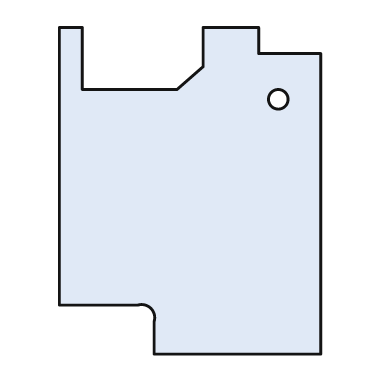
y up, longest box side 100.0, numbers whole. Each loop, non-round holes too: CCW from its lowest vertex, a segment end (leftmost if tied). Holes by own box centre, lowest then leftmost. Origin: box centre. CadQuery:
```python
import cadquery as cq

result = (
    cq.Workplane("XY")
    .moveTo(-11.0, -50.0)
    .lineTo(40.0, -50.0)
    .lineTo(40.0, 42.0)
    .lineTo(21.0, 42.0)
    .lineTo(21.0, 50.0)
    .lineTo(4.0, 50.0)
    .lineTo(4.0, 38.0)
    .lineTo(-4.0, 31.0)
    .lineTo(-33.0, 31.0)
    .lineTo(-33.0, 50.0)
    .lineTo(-40.0, 50.0)
    .lineTo(-40.0, -35.0)
    .lineTo(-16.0, -35.0)
    .threePointArc((-12.0, -36.0), (-11.0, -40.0))
    .close()
    .moveTo(27.0, 28.0)
    .circle(3.0)
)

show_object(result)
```